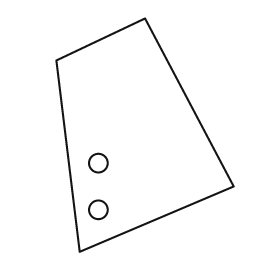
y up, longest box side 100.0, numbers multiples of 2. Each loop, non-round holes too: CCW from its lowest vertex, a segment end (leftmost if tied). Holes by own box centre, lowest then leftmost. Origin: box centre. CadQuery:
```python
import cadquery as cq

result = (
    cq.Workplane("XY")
    .moveTo(-28.0, -50.0)
    .lineTo(38.0, -22.0)
    .lineTo(0.0, 50.0)
    .lineTo(-38.0, 32.0)
    .close()
    .moveTo(-20.0, -32.0)
    .circle(4.0)
    .moveTo(-20.0, -12.0)
    .circle(4.0)
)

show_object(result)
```